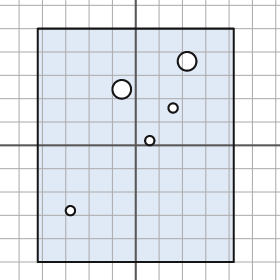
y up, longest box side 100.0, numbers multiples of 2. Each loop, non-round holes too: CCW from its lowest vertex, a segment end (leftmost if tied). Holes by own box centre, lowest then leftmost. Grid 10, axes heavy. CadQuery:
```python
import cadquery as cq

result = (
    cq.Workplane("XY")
    .moveTo(-42.0, -50.0)
    .lineTo(42.0, -50.0)
    .lineTo(42.0, 50.0)
    .lineTo(-42.0, 50.0)
    .close()
    .moveTo(-28.0, -28.0)
    .circle(2.0)
    .moveTo(6.0, 2.0)
    .circle(2.0)
    .moveTo(16.0, 16.0)
    .circle(2.0)
    .moveTo(-6.0, 24.0)
    .circle(4.0)
    .moveTo(22.0, 36.0)
    .circle(4.0)
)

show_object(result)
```